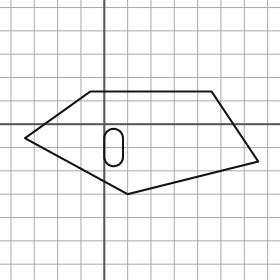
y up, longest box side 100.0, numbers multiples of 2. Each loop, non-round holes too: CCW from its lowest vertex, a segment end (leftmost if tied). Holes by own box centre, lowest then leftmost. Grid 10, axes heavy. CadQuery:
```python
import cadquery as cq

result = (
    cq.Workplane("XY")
    .moveTo(10.0, -30.0)
    .lineTo(66.0, -16.0)
    .lineTo(46.0, 14.0)
    .lineTo(-6.0, 14.0)
    .lineTo(-34.0, -6.0)
    .close()
    .moveTo(0.0, -14.0)
    .threePointArc((4.0, -18.0), (8.0, -14.0))
    .lineTo(8.0, -6.0)
    .threePointArc((4.0, -2.0), (0.0, -6.0))
    .close()
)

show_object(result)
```